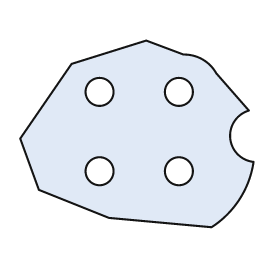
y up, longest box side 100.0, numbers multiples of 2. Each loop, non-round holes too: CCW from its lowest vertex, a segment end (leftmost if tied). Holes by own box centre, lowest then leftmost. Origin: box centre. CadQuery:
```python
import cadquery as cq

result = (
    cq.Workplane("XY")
    .moveTo(32.0, -40.0)
    .threePointArc((44.0, -28.0), (50.0, -12.0))
    .threePointArc((40.0, -2.0), (48.0, 10.0))
    .lineTo(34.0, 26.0)
    .threePointArc((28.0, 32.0), (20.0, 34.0))
    .lineTo(4.0, 40.0)
    .lineTo(-28.0, 30.0)
    .lineTo(-50.0, -2.0)
    .lineTo(-42.0, -24.0)
    .lineTo(-12.0, -36.0)
    .close()
    .moveTo(-16.0, -16.0)
    .circle(6.0)
    .moveTo(18.0, -16.0)
    .circle(6.0)
    .moveTo(-16.0, 18.0)
    .circle(6.0)
    .moveTo(18.0, 18.0)
    .circle(6.0)
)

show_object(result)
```